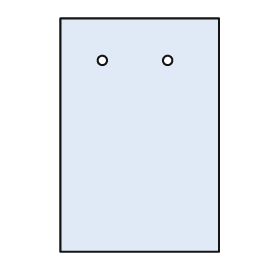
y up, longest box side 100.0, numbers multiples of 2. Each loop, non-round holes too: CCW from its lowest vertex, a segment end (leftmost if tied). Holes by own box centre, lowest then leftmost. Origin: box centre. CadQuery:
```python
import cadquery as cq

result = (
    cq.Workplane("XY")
    .moveTo(-34.0, -50.0)
    .lineTo(34.0, -50.0)
    .lineTo(34.0, 50.0)
    .lineTo(-34.0, 50.0)
    .close()
    .moveTo(-16.0, 32.0)
    .circle(2.0)
    .moveTo(12.0, 32.0)
    .circle(2.0)
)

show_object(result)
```